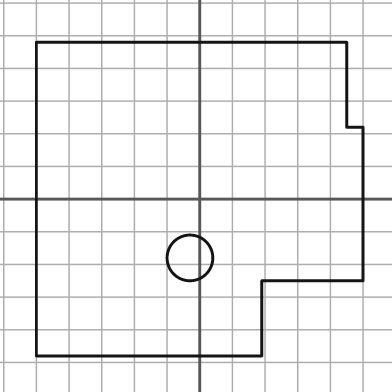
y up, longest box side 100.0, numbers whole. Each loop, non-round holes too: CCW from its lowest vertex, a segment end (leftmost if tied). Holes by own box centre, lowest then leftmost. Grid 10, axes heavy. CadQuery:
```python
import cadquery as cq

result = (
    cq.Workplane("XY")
    .moveTo(-50.0, -48.0)
    .lineTo(19.0, -48.0)
    .lineTo(19.0, -25.0)
    .lineTo(50.0, -25.0)
    .lineTo(50.0, 22.0)
    .lineTo(45.0, 22.0)
    .lineTo(45.0, 48.0)
    .lineTo(-50.0, 48.0)
    .close()
    .moveTo(-3.0, -18.0)
    .circle(7.0)
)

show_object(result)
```